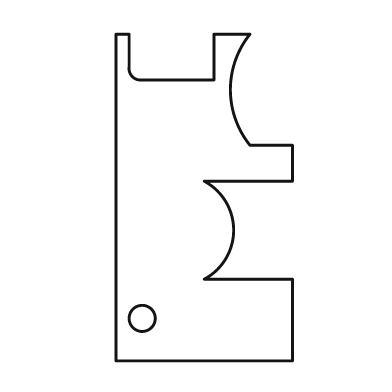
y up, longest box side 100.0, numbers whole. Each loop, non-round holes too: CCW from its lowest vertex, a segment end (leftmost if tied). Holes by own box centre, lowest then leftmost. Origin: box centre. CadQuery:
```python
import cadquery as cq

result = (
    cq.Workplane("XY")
    .moveTo(-27.0, -50.0)
    .lineTo(27.0, -50.0)
    .lineTo(27.0, -25.0)
    .lineTo(0.0, -25.0)
    .threePointArc((9.0, -10.0), (0.0, 5.0))
    .lineTo(27.0, 5.0)
    .lineTo(27.0, 16.0)
    .lineTo(14.0, 16.0)
    .threePointArc((8.0, 33.0), (14.0, 50.0))
    .lineTo(3.0, 50.0)
    .lineTo(3.0, 36.0)
    .lineTo(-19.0, 36.0)
    .threePointArc((-22.0, 37.0), (-23.0, 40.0))
    .lineTo(-23.0, 50.0)
    .lineTo(-27.0, 50.0)
    .close()
    .moveTo(-19.0, -37.0)
    .circle(4.0)
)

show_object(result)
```